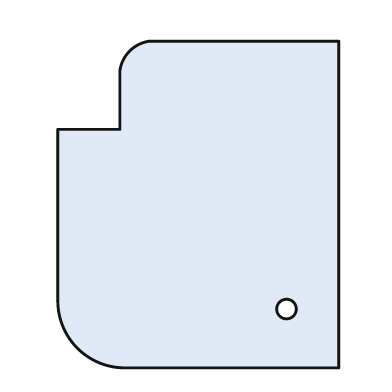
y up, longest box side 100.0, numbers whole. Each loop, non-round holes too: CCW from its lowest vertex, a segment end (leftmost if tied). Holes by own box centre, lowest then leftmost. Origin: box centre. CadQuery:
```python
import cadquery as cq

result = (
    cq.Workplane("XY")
    .moveTo(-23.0, -50.0)
    .lineTo(43.0, -50.0)
    .lineTo(43.0, 50.0)
    .lineTo(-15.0, 50.0)
    .threePointArc((-21.0, 47.0), (-24.0, 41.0))
    .lineTo(-24.0, 23.0)
    .lineTo(-43.0, 23.0)
    .lineTo(-43.0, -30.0)
    .threePointArc((-37.0, -44.0), (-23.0, -50.0))
    .close()
    .moveTo(27.0, -32.0)
    .circle(3.0)
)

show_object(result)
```